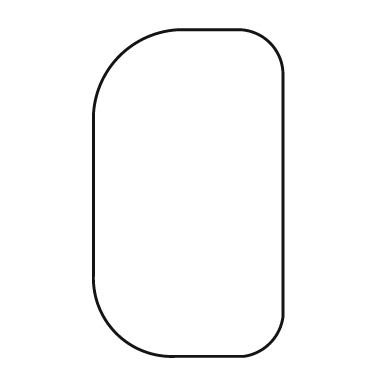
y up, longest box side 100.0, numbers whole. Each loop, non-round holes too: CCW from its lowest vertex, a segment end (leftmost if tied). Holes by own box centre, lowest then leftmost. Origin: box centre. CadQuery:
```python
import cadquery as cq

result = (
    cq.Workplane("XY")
    .moveTo(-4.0, -50.0)
    .lineTo(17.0, -50.0)
    .threePointArc((25.0, -46.0), (29.0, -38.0))
    .lineTo(29.0, 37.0)
    .threePointArc((25.0, 46.0), (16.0, 50.0))
    .lineTo(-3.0, 50.0)
    .threePointArc((-21.0, 42.0), (-29.0, 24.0))
    .lineTo(-29.0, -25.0)
    .threePointArc((-22.0, -43.0), (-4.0, -50.0))
    .close()
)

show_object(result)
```